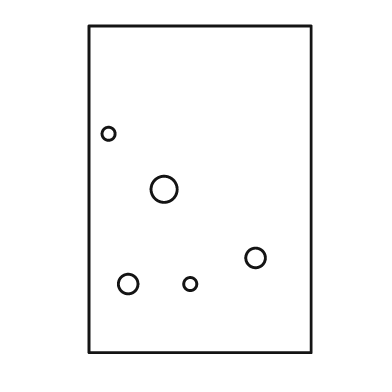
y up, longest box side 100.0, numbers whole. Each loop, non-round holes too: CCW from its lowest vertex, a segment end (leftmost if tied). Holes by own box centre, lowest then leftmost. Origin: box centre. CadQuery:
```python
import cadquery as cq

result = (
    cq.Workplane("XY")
    .moveTo(-34.0, -50.0)
    .lineTo(34.0, -50.0)
    .lineTo(34.0, 50.0)
    .lineTo(-34.0, 50.0)
    .close()
    .moveTo(-22.0, -29.0)
    .circle(3.0)
    .moveTo(-3.0, -29.0)
    .circle(2.0)
    .moveTo(17.0, -21.0)
    .circle(3.0)
    .moveTo(-11.0, 0.0)
    .circle(4.0)
    .moveTo(-28.0, 17.0)
    .circle(2.0)
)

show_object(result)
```